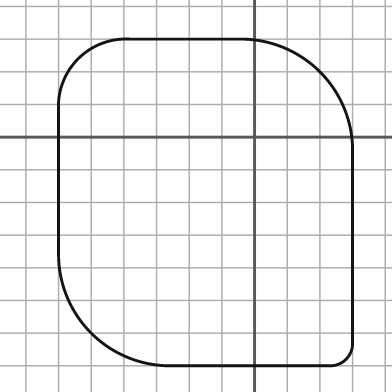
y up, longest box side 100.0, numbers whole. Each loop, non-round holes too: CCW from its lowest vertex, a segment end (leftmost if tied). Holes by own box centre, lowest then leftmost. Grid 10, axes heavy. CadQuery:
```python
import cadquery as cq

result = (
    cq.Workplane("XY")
    .moveTo(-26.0, -70.0)
    .lineTo(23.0, -70.0)
    .threePointArc((28.0, -68.0), (30.0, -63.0))
    .lineTo(30.0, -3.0)
    .threePointArc((20.0, 20.0), (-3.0, 30.0))
    .lineTo(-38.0, 30.0)
    .threePointArc((-54.0, 24.0), (-60.0, 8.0))
    .lineTo(-60.0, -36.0)
    .threePointArc((-50.0, -60.0), (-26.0, -70.0))
    .close()
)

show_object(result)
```